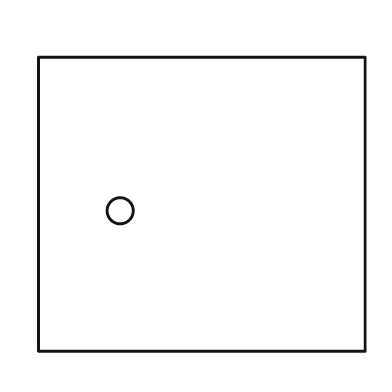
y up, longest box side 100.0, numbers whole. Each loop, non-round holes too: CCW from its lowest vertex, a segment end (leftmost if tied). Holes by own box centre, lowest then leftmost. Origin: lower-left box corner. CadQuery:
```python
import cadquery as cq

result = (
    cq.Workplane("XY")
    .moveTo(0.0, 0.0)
    .lineTo(100.0, 0.0)
    .lineTo(100.0, 90.0)
    .lineTo(0.0, 90.0)
    .close()
    .moveTo(25.0, 43.0)
    .circle(4.0)
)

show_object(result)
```